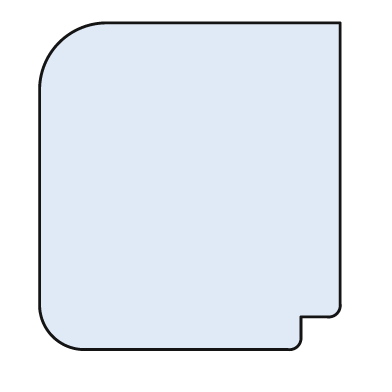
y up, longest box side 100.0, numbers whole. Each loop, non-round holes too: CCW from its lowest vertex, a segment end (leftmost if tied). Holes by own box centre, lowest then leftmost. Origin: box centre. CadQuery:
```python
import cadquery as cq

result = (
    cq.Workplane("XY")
    .moveTo(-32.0, -50.0)
    .lineTo(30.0, -50.0)
    .threePointArc((33.0, -49.0), (34.0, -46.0))
    .lineTo(34.0, -40.0)
    .lineTo(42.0, -40.0)
    .threePointArc((45.0, -39.0), (46.0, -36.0))
    .lineTo(46.0, 50.0)
    .lineTo(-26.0, 50.0)
    .threePointArc((-40.0, 44.0), (-46.0, 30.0))
    .lineTo(-46.0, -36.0)
    .threePointArc((-42.0, -46.0), (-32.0, -50.0))
    .close()
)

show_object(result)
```